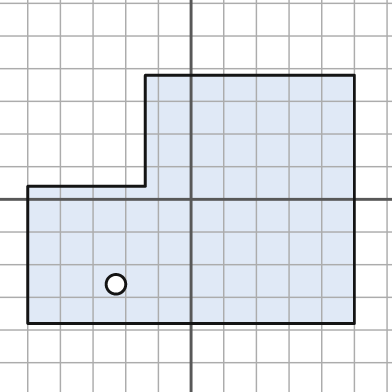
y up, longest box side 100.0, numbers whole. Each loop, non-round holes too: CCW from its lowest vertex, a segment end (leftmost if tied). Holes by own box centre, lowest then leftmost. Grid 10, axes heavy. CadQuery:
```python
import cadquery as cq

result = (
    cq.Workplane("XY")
    .moveTo(-50.0, -38.0)
    .lineTo(50.0, -38.0)
    .lineTo(50.0, 38.0)
    .lineTo(-14.0, 38.0)
    .lineTo(-14.0, 4.0)
    .lineTo(-50.0, 4.0)
    .close()
    .moveTo(-23.0, -26.0)
    .circle(3.0)
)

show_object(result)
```